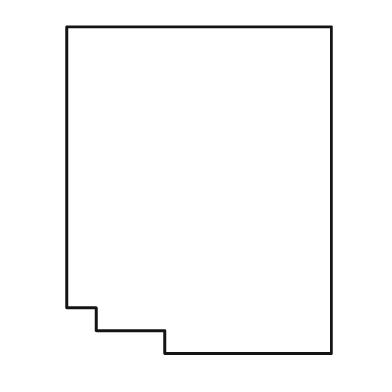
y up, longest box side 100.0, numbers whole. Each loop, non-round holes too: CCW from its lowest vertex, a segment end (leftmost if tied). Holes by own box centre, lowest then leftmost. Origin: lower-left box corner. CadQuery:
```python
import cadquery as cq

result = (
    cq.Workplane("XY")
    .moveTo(30.0, 0.0)
    .lineTo(81.0, 0.0)
    .lineTo(81.0, 100.0)
    .lineTo(0.0, 100.0)
    .lineTo(0.0, 14.0)
    .lineTo(9.0, 14.0)
    .lineTo(9.0, 7.0)
    .lineTo(30.0, 7.0)
    .close()
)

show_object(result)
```